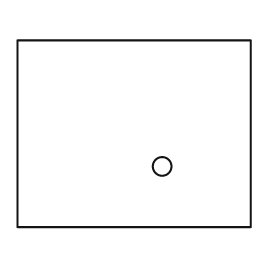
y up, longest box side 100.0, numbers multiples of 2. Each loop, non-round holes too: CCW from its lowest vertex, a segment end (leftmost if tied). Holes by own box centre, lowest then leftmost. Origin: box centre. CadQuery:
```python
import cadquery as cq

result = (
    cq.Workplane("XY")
    .moveTo(-50.0, -40.0)
    .lineTo(50.0, -40.0)
    .lineTo(50.0, 40.0)
    .lineTo(-50.0, 40.0)
    .close()
    .moveTo(12.0, -14.0)
    .circle(4.0)
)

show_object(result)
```